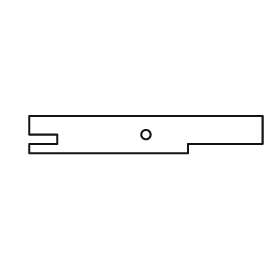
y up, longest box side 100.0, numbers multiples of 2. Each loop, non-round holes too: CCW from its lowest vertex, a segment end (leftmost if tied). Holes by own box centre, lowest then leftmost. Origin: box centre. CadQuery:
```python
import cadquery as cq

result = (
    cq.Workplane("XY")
    .moveTo(-50.0, -8.0)
    .lineTo(18.0, -8.0)
    .lineTo(18.0, -4.0)
    .lineTo(50.0, -4.0)
    .lineTo(50.0, 8.0)
    .lineTo(-50.0, 8.0)
    .lineTo(-50.0, 0.0)
    .lineTo(-38.0, 0.0)
    .lineTo(-38.0, -4.0)
    .lineTo(-50.0, -4.0)
    .close()
    .moveTo(0.0, 0.0)
    .circle(2.0)
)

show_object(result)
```